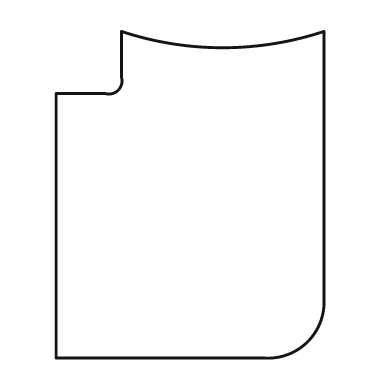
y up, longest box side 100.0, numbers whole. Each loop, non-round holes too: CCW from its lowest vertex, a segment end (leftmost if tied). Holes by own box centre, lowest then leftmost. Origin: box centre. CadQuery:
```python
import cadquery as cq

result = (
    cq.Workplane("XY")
    .moveTo(-41.0, -50.0)
    .lineTo(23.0, -50.0)
    .threePointArc((36.0, -45.0), (41.0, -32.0))
    .lineTo(41.0, 50.0)
    .threePointArc((10.0, 45.0), (-21.0, 50.0))
    .lineTo(-21.0, 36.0)
    .threePointArc((-22.0, 32.0), (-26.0, 31.0))
    .lineTo(-41.0, 31.0)
    .close()
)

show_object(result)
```